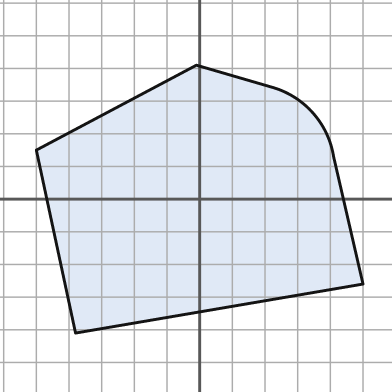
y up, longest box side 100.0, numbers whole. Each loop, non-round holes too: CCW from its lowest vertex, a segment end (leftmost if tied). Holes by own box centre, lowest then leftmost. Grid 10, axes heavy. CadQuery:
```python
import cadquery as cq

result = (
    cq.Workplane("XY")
    .moveTo(-38.0, -41.0)
    .lineTo(50.0, -26.0)
    .lineTo(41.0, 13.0)
    .threePointArc((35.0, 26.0), (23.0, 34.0))
    .lineTo(-1.0, 41.0)
    .lineTo(-50.0, 15.0)
    .close()
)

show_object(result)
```